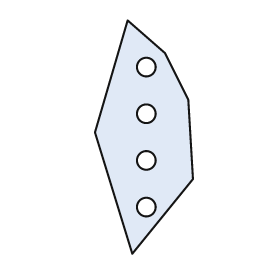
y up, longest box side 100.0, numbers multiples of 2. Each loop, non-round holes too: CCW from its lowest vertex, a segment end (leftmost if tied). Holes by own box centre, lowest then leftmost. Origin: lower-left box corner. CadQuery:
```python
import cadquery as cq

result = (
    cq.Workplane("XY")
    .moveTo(16.0, 0.0)
    .lineTo(42.0, 32.0)
    .lineTo(40.0, 66.0)
    .lineTo(30.0, 86.0)
    .lineTo(14.0, 100.0)
    .lineTo(0.0, 52.0)
    .close()
    .moveTo(22.0, 20.0)
    .circle(4.0)
    .moveTo(22.0, 40.0)
    .circle(4.0)
    .moveTo(22.0, 60.0)
    .circle(4.0)
    .moveTo(22.0, 80.0)
    .circle(4.0)
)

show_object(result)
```